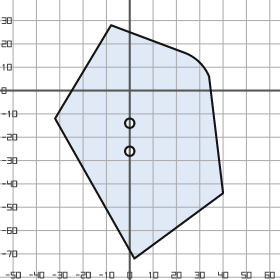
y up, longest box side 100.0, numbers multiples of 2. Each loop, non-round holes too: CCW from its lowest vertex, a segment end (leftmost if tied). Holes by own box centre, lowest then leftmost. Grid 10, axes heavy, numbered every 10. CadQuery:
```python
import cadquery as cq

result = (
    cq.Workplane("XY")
    .moveTo(2.0, -72.0)
    .lineTo(40.0, -44.0)
    .lineTo(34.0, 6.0)
    .threePointArc((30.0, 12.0), (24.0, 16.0))
    .lineTo(-8.0, 28.0)
    .lineTo(-32.0, -12.0)
    .close()
    .moveTo(0.0, -26.0)
    .circle(2.0)
    .moveTo(0.0, -14.0)
    .circle(2.0)
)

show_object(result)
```